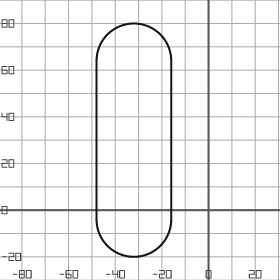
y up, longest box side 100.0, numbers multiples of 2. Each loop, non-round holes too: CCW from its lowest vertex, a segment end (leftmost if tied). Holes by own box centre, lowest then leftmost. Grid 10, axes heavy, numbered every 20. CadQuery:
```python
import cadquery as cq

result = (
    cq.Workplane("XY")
    .moveTo(-48.0, -4.0)
    .threePointArc((-32.0, -20.0), (-16.0, -4.0))
    .lineTo(-16.0, 64.0)
    .threePointArc((-32.0, 80.0), (-48.0, 64.0))
    .close()
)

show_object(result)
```